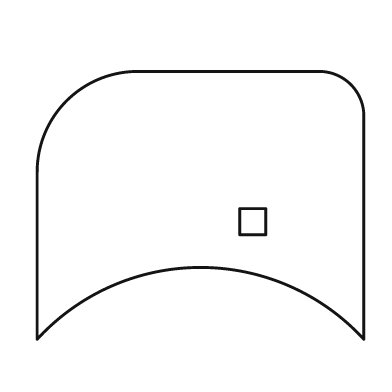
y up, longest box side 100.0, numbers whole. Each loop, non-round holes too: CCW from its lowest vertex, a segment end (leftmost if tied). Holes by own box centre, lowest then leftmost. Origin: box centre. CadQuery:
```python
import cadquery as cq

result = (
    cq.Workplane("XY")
    .moveTo(-50.0, -41.0)
    .threePointArc((0.0, -19.0), (50.0, -41.0))
    .lineTo(50.0, 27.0)
    .threePointArc((46.0, 37.0), (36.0, 41.0))
    .lineTo(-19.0, 41.0)
    .threePointArc((-41.0, 32.0), (-50.0, 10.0))
    .close()
    .moveTo(12.0, -9.0)
    .lineTo(20.0, -9.0)
    .lineTo(20.0, -1.0)
    .lineTo(12.0, -1.0)
    .close()
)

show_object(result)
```